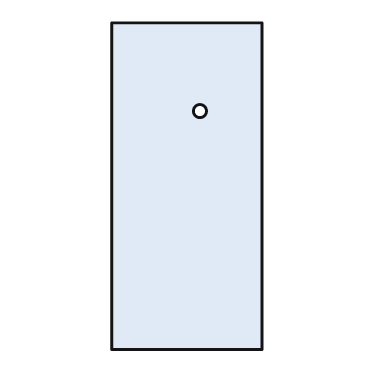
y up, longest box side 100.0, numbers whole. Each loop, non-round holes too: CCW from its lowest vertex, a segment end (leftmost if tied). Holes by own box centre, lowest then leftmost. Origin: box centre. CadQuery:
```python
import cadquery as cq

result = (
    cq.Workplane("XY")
    .moveTo(-23.0, -50.0)
    .lineTo(23.0, -50.0)
    .lineTo(23.0, 50.0)
    .lineTo(-23.0, 50.0)
    .close()
    .moveTo(4.0, 23.0)
    .circle(2.0)
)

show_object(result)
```